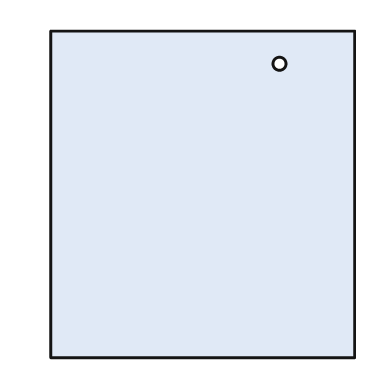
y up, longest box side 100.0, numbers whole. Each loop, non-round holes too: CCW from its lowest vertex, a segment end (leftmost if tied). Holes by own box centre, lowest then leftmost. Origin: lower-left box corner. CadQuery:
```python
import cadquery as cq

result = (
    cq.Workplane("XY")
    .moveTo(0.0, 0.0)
    .lineTo(93.0, 0.0)
    .lineTo(93.0, 100.0)
    .lineTo(0.0, 100.0)
    .close()
    .moveTo(70.0, 90.0)
    .circle(2.0)
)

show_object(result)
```